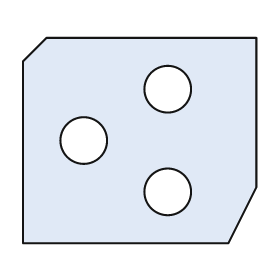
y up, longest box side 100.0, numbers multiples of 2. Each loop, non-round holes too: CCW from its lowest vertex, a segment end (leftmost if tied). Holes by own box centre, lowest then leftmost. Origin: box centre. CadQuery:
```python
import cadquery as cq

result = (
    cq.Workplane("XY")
    .moveTo(-50.0, -44.0)
    .lineTo(38.0, -44.0)
    .lineTo(50.0, -20.0)
    .lineTo(50.0, 44.0)
    .lineTo(-40.0, 44.0)
    .lineTo(-50.0, 34.0)
    .close()
    .moveTo(12.0, -22.0)
    .circle(10.0)
    .moveTo(-24.0, 0.0)
    .circle(10.0)
    .moveTo(12.0, 22.0)
    .circle(10.0)
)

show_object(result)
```